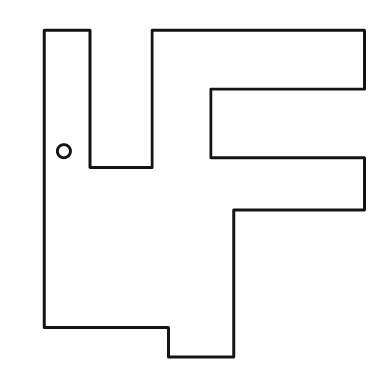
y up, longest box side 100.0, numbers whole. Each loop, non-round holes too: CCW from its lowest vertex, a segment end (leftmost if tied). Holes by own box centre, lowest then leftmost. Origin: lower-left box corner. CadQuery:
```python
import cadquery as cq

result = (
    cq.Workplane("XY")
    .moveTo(38.0, 0.0)
    .lineTo(58.0, 0.0)
    .lineTo(58.0, 45.0)
    .lineTo(98.0, 45.0)
    .lineTo(98.0, 61.0)
    .lineTo(51.0, 61.0)
    .lineTo(51.0, 82.0)
    .lineTo(98.0, 82.0)
    .lineTo(98.0, 100.0)
    .lineTo(33.0, 100.0)
    .lineTo(33.0, 58.0)
    .lineTo(14.0, 58.0)
    .lineTo(14.0, 100.0)
    .lineTo(0.0, 100.0)
    .lineTo(0.0, 9.0)
    .lineTo(38.0, 9.0)
    .close()
    .moveTo(6.0, 63.0)
    .circle(2.0)
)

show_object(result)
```